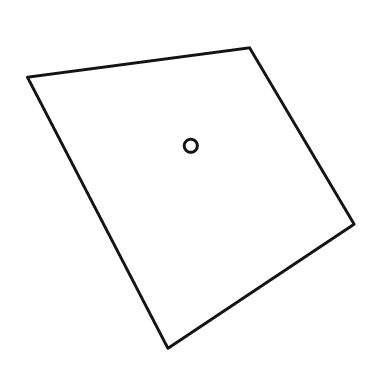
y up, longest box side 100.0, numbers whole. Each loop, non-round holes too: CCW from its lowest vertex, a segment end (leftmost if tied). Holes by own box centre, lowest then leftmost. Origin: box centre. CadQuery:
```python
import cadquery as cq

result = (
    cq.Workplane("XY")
    .moveTo(-7.0, -46.0)
    .lineTo(50.0, -8.0)
    .lineTo(18.0, 46.0)
    .lineTo(-50.0, 37.0)
    .close()
    .moveTo(0.0, 16.0)
    .circle(2.0)
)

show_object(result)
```